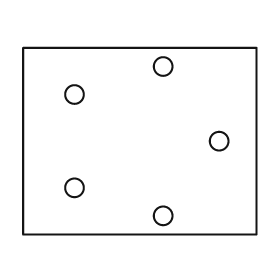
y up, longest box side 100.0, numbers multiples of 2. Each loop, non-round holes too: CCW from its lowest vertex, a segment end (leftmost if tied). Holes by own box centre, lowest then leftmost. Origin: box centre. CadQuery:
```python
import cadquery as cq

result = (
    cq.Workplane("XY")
    .moveTo(-50.0, -40.0)
    .lineTo(50.0, -40.0)
    .lineTo(50.0, 40.0)
    .lineTo(-50.0, 40.0)
    .close()
    .moveTo(10.0, -32.0)
    .circle(4.0)
    .moveTo(-28.0, -20.0)
    .circle(4.0)
    .moveTo(34.0, 0.0)
    .circle(4.0)
    .moveTo(-28.0, 20.0)
    .circle(4.0)
    .moveTo(10.0, 32.0)
    .circle(4.0)
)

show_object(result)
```